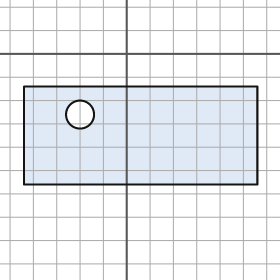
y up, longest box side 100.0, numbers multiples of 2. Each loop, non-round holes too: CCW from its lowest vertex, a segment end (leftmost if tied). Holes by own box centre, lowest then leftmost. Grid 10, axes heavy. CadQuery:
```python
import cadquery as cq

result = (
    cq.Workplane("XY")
    .moveTo(-44.0, -56.0)
    .lineTo(56.0, -56.0)
    .lineTo(56.0, -14.0)
    .lineTo(-44.0, -14.0)
    .close()
    .moveTo(-20.0, -26.0)
    .circle(6.0)
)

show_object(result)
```